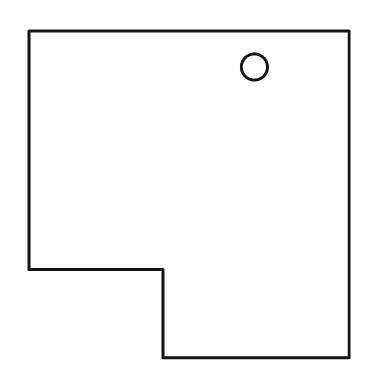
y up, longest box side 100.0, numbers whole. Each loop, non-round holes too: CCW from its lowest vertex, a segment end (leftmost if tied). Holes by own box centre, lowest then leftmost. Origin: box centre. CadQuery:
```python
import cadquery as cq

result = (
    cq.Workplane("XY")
    .moveTo(-8.0, -50.0)
    .lineTo(49.0, -50.0)
    .lineTo(49.0, 50.0)
    .lineTo(-49.0, 50.0)
    .lineTo(-49.0, -23.0)
    .lineTo(-8.0, -23.0)
    .close()
    .moveTo(20.0, 39.0)
    .circle(4.0)
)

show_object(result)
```